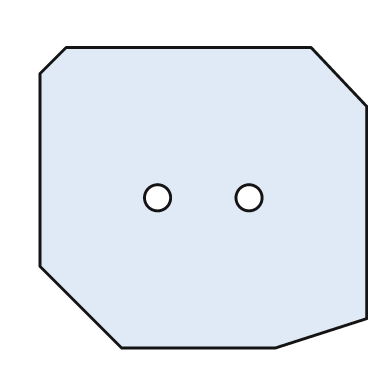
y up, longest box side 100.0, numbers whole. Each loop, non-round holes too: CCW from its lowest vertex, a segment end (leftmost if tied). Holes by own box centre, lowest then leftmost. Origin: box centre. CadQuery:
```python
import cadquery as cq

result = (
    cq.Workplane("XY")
    .moveTo(-25.0, -46.0)
    .lineTo(22.0, -46.0)
    .lineTo(50.0, -37.0)
    .lineTo(50.0, 28.0)
    .lineTo(33.0, 46.0)
    .lineTo(-42.0, 46.0)
    .lineTo(-50.0, 38.0)
    .lineTo(-50.0, -21.0)
    .close()
    .moveTo(-14.0, 0.0)
    .circle(4.0)
    .moveTo(14.0, 0.0)
    .circle(4.0)
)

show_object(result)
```